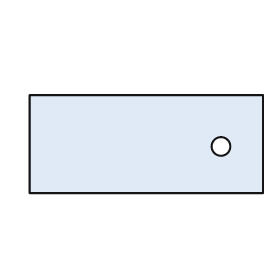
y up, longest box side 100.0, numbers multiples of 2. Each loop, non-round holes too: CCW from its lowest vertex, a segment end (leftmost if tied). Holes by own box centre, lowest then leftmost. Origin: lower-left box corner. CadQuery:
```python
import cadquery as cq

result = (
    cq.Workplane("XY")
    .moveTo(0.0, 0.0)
    .lineTo(100.0, 0.0)
    .lineTo(100.0, 42.0)
    .lineTo(0.0, 42.0)
    .close()
    .moveTo(82.0, 20.0)
    .circle(4.0)
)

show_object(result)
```